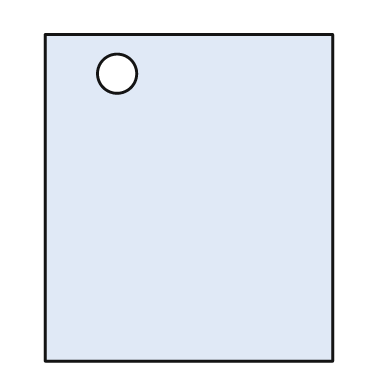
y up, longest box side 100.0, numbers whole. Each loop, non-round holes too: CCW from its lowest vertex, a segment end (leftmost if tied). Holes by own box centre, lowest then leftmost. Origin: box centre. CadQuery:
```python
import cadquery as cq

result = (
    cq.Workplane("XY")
    .moveTo(-44.0, -50.0)
    .lineTo(44.0, -50.0)
    .lineTo(44.0, 50.0)
    .lineTo(-44.0, 50.0)
    .close()
    .moveTo(-22.0, 38.0)
    .circle(6.0)
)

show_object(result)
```